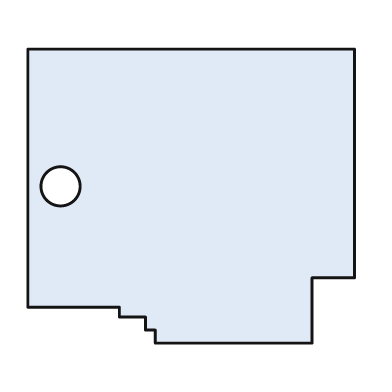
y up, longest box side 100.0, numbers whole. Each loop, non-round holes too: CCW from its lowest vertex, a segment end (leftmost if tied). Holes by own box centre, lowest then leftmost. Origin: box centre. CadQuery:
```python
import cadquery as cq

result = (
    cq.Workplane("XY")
    .moveTo(-11.0, -45.0)
    .lineTo(37.0, -45.0)
    .lineTo(37.0, -25.0)
    .lineTo(50.0, -25.0)
    .lineTo(50.0, 45.0)
    .lineTo(-50.0, 45.0)
    .lineTo(-50.0, -34.0)
    .lineTo(-22.0, -34.0)
    .lineTo(-22.0, -37.0)
    .lineTo(-14.0, -37.0)
    .lineTo(-14.0, -41.0)
    .lineTo(-11.0, -41.0)
    .close()
    .moveTo(-40.0, 3.0)
    .circle(6.0)
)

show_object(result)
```